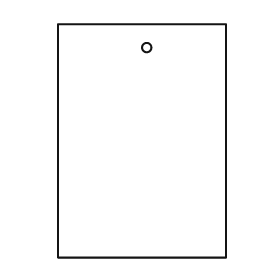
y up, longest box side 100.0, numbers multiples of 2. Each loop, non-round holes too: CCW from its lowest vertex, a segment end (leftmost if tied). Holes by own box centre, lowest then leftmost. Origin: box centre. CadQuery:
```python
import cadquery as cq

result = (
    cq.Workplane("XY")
    .moveTo(-36.0, -50.0)
    .lineTo(36.0, -50.0)
    .lineTo(36.0, 50.0)
    .lineTo(-36.0, 50.0)
    .close()
    .moveTo(2.0, 40.0)
    .circle(2.0)
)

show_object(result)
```